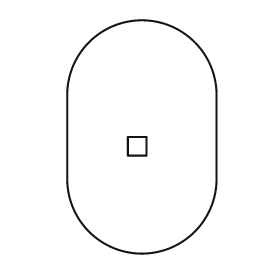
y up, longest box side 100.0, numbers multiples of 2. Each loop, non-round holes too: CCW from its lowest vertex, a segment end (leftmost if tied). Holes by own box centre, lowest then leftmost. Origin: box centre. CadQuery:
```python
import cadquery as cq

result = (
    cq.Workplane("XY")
    .moveTo(-32.0, -18.0)
    .threePointArc((0.0, -50.0), (32.0, -18.0))
    .lineTo(32.0, 18.0)
    .threePointArc((0.0, 50.0), (-32.0, 18.0))
    .close()
    .moveTo(-6.0, -8.0)
    .lineTo(2.0, -8.0)
    .lineTo(2.0, 0.0)
    .lineTo(-6.0, 0.0)
    .close()
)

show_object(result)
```